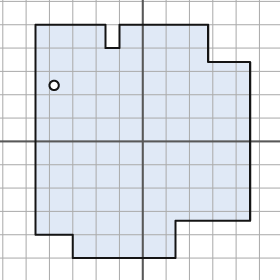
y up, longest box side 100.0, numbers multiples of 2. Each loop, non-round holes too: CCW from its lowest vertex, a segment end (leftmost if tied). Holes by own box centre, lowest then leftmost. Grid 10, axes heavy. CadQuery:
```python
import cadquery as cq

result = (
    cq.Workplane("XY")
    .moveTo(-30.0, -50.0)
    .lineTo(14.0, -50.0)
    .lineTo(14.0, -34.0)
    .lineTo(46.0, -34.0)
    .lineTo(46.0, 34.0)
    .lineTo(28.0, 34.0)
    .lineTo(28.0, 50.0)
    .lineTo(-10.0, 50.0)
    .lineTo(-10.0, 40.0)
    .lineTo(-16.0, 40.0)
    .lineTo(-16.0, 50.0)
    .lineTo(-46.0, 50.0)
    .lineTo(-46.0, -40.0)
    .lineTo(-30.0, -40.0)
    .close()
    .moveTo(-38.0, 24.0)
    .circle(2.0)
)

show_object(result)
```